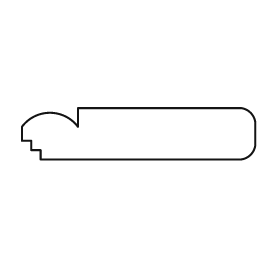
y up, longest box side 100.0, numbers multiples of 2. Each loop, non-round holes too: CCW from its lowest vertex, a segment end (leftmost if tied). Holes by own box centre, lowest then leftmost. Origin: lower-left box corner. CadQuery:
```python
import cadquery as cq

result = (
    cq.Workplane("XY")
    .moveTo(8.0, 0.0)
    .lineTo(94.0, 0.0)
    .threePointArc((98.0, 2.0), (100.0, 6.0))
    .lineTo(100.0, 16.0)
    .threePointArc((98.0, 20.0), (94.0, 22.0))
    .lineTo(24.0, 22.0)
    .lineTo(24.0, 14.0)
    .threePointArc((12.0, 20.0), (0.0, 14.0))
    .lineTo(0.0, 8.0)
    .lineTo(4.0, 8.0)
    .lineTo(4.0, 4.0)
    .lineTo(8.0, 4.0)
    .close()
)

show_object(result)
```